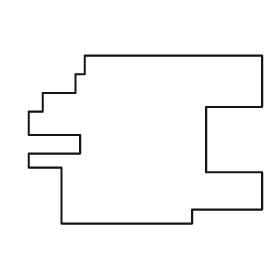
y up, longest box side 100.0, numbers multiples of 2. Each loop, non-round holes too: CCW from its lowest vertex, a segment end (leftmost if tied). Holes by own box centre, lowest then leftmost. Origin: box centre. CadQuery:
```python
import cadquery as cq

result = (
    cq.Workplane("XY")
    .moveTo(-36.0, -36.0)
    .lineTo(20.0, -36.0)
    .lineTo(20.0, -30.0)
    .lineTo(50.0, -30.0)
    .lineTo(50.0, -14.0)
    .lineTo(26.0, -14.0)
    .lineTo(26.0, 14.0)
    .lineTo(50.0, 14.0)
    .lineTo(50.0, 36.0)
    .lineTo(-26.0, 36.0)
    .lineTo(-26.0, 28.0)
    .lineTo(-30.0, 28.0)
    .lineTo(-30.0, 20.0)
    .lineTo(-44.0, 20.0)
    .lineTo(-44.0, 12.0)
    .lineTo(-50.0, 12.0)
    .lineTo(-50.0, 2.0)
    .lineTo(-28.0, 2.0)
    .lineTo(-28.0, -6.0)
    .lineTo(-50.0, -6.0)
    .lineTo(-50.0, -12.0)
    .lineTo(-36.0, -12.0)
    .close()
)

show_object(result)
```